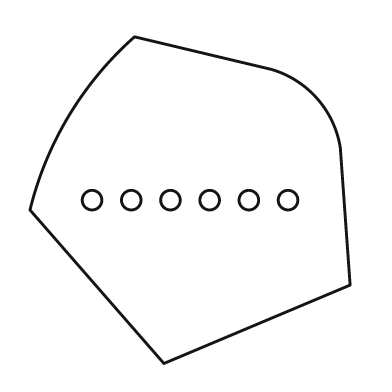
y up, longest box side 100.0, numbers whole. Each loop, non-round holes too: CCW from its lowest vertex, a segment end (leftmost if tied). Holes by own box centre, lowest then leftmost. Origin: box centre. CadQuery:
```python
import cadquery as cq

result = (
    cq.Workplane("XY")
    .moveTo(-8.0, -50.0)
    .lineTo(49.0, -26.0)
    .lineTo(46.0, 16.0)
    .threePointArc((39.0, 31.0), (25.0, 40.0))
    .lineTo(-17.0, 50.0)
    .threePointArc((-37.0, 26.0), (-49.0, -3.0))
    .close()
    .moveTo(-30.0, 0.0)
    .circle(3.0)
    .moveTo(-18.0, 0.0)
    .circle(3.0)
    .moveTo(-6.0, 0.0)
    .circle(3.0)
    .moveTo(6.0, 0.0)
    .circle(3.0)
    .moveTo(18.0, 0.0)
    .circle(3.0)
    .moveTo(30.0, 0.0)
    .circle(3.0)
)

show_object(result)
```